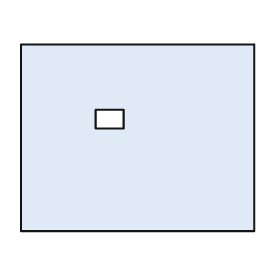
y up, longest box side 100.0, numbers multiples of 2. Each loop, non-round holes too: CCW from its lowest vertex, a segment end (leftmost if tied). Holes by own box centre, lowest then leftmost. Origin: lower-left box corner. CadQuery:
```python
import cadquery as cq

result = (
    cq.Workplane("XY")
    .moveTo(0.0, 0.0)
    .lineTo(100.0, 0.0)
    .lineTo(100.0, 80.0)
    .lineTo(0.0, 80.0)
    .close()
    .moveTo(32.0, 44.0)
    .lineTo(44.0, 44.0)
    .lineTo(44.0, 52.0)
    .lineTo(32.0, 52.0)
    .close()
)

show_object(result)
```